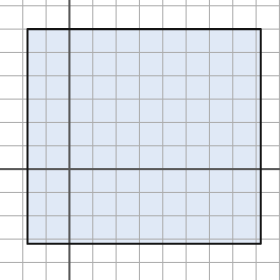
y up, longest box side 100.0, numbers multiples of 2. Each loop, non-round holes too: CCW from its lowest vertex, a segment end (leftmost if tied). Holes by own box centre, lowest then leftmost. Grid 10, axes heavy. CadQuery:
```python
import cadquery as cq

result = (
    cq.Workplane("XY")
    .moveTo(-18.0, -32.0)
    .lineTo(82.0, -32.0)
    .lineTo(82.0, 60.0)
    .lineTo(-18.0, 60.0)
    .close()
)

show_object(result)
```